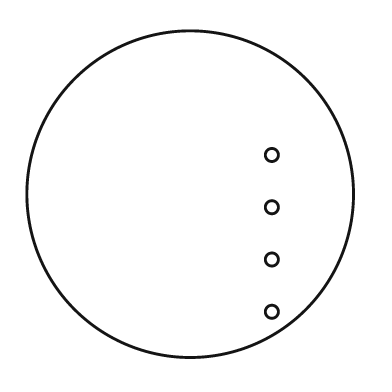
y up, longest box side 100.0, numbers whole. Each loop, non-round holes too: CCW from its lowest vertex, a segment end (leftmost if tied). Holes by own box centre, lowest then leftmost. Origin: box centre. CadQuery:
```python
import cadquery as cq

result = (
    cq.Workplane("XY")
    .moveTo(0.0, 0.0)
    .circle(50.0)
    .moveTo(25.0, -36.0)
    .circle(2.0)
    .moveTo(25.0, -20.0)
    .circle(2.0)
    .moveTo(25.0, -4.0)
    .circle(2.0)
    .moveTo(25.0, 12.0)
    .circle(2.0)
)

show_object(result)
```